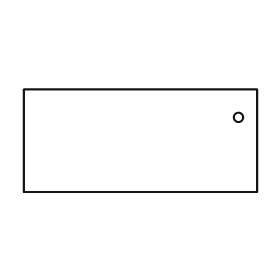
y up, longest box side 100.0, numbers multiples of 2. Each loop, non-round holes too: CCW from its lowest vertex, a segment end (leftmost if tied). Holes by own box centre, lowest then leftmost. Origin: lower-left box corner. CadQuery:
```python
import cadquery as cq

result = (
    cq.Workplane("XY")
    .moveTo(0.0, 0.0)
    .lineTo(100.0, 0.0)
    .lineTo(100.0, 44.0)
    .lineTo(0.0, 44.0)
    .close()
    .moveTo(92.0, 32.0)
    .circle(2.0)
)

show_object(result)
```